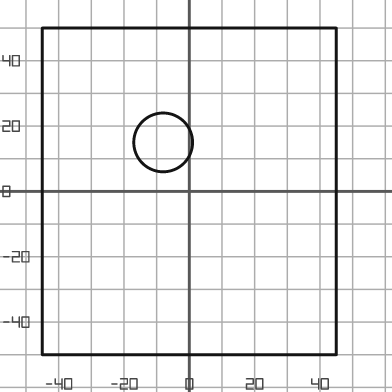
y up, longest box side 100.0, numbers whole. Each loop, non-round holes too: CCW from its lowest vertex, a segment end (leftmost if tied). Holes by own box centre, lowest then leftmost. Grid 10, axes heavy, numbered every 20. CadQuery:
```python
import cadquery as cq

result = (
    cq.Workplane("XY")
    .moveTo(-45.0, -50.0)
    .lineTo(45.0, -50.0)
    .lineTo(45.0, 50.0)
    .lineTo(-45.0, 50.0)
    .close()
    .moveTo(-8.0, 15.0)
    .circle(9.0)
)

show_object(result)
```